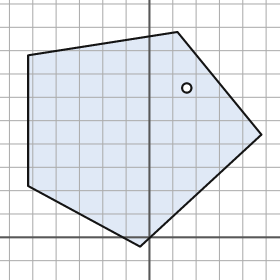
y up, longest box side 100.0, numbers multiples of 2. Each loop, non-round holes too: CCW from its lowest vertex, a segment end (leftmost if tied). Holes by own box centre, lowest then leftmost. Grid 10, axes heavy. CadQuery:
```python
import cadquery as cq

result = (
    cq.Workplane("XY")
    .moveTo(-4.0, -4.0)
    .lineTo(48.0, 44.0)
    .lineTo(12.0, 88.0)
    .lineTo(-52.0, 78.0)
    .lineTo(-52.0, 22.0)
    .close()
    .moveTo(16.0, 64.0)
    .circle(2.0)
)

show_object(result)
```